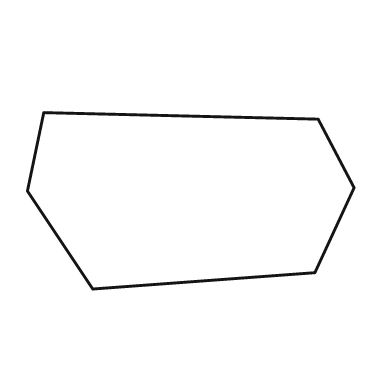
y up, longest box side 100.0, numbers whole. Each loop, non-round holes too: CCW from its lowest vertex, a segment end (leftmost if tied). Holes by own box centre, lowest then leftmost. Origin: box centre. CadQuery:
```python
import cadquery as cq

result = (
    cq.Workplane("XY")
    .moveTo(-30.0, -27.0)
    .lineTo(38.0, -22.0)
    .lineTo(50.0, 4.0)
    .lineTo(39.0, 25.0)
    .lineTo(-45.0, 27.0)
    .lineTo(-50.0, 3.0)
    .close()
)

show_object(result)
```